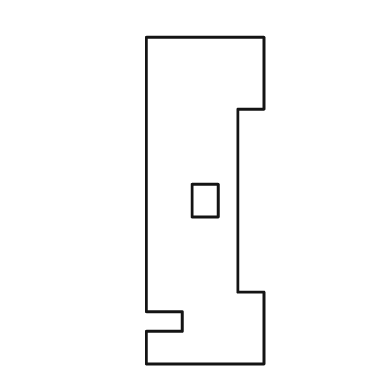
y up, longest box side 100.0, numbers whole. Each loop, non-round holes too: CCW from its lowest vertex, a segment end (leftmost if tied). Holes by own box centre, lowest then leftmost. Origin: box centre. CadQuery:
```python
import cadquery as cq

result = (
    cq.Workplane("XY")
    .moveTo(-18.0, -50.0)
    .lineTo(18.0, -50.0)
    .lineTo(18.0, -28.0)
    .lineTo(10.0, -28.0)
    .lineTo(10.0, 28.0)
    .lineTo(18.0, 28.0)
    .lineTo(18.0, 50.0)
    .lineTo(-18.0, 50.0)
    .lineTo(-18.0, -34.0)
    .lineTo(-7.0, -34.0)
    .lineTo(-7.0, -40.0)
    .lineTo(-18.0, -40.0)
    .close()
    .moveTo(-4.0, -5.0)
    .lineTo(4.0, -5.0)
    .lineTo(4.0, 5.0)
    .lineTo(-4.0, 5.0)
    .close()
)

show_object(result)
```